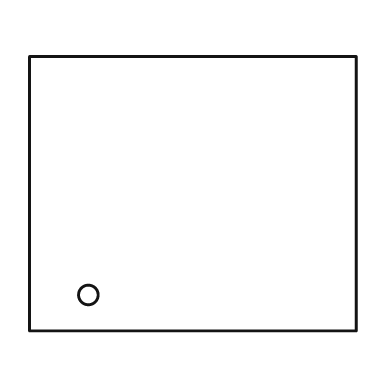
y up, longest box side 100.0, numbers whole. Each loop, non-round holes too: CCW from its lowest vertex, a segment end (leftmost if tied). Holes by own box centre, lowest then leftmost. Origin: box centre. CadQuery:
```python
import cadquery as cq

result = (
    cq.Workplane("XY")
    .moveTo(-50.0, -42.0)
    .lineTo(50.0, -42.0)
    .lineTo(50.0, 42.0)
    .lineTo(-50.0, 42.0)
    .close()
    .moveTo(-32.0, -31.0)
    .circle(3.0)
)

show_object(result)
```